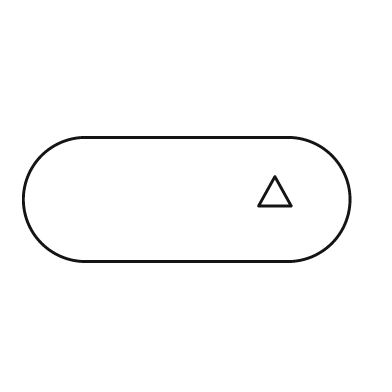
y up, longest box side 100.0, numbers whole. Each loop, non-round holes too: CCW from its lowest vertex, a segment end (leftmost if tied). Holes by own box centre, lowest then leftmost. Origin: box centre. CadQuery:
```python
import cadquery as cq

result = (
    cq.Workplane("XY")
    .moveTo(-31.0, -19.0)
    .lineTo(31.0, -19.0)
    .threePointArc((50.0, 0.0), (31.0, 19.0))
    .lineTo(-31.0, 19.0)
    .threePointArc((-50.0, 0.0), (-31.0, -19.0))
    .close()
    .moveTo(22.0, -2.0)
    .lineTo(32.0, -2.0)
    .lineTo(27.0, 7.0)
    .close()
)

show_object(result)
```